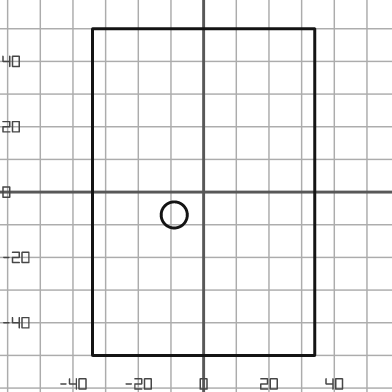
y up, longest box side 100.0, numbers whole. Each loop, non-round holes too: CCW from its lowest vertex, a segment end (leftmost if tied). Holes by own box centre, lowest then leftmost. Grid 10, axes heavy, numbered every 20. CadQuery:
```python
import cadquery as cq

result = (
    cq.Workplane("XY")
    .moveTo(-34.0, -50.0)
    .lineTo(34.0, -50.0)
    .lineTo(34.0, 50.0)
    .lineTo(-34.0, 50.0)
    .close()
    .moveTo(-9.0, -7.0)
    .circle(4.0)
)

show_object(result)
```